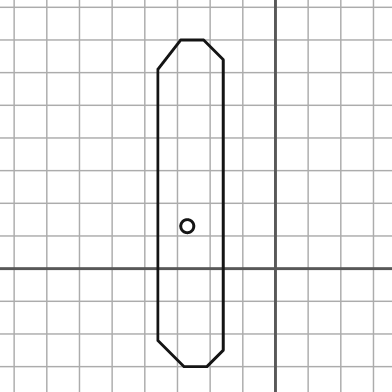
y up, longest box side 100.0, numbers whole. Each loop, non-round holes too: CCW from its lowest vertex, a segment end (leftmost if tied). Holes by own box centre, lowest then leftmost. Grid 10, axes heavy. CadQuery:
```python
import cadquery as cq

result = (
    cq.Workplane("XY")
    .moveTo(-28.0, -30.0)
    .lineTo(-21.0, -30.0)
    .lineTo(-16.0, -25.0)
    .lineTo(-16.0, 64.0)
    .lineTo(-22.0, 70.0)
    .lineTo(-29.0, 70.0)
    .lineTo(-36.0, 61.0)
    .lineTo(-36.0, -22.0)
    .close()
    .moveTo(-27.0, 13.0)
    .circle(2.0)
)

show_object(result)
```